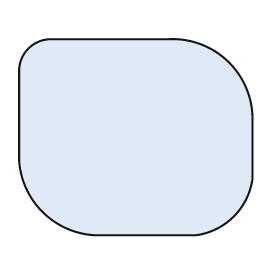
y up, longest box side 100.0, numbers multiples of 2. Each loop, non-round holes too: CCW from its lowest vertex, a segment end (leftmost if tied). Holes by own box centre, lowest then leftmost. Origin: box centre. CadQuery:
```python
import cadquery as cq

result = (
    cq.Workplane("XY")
    .moveTo(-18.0, -42.0)
    .lineTo(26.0, -42.0)
    .threePointArc((42.0, -34.0), (50.0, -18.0))
    .lineTo(50.0, 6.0)
    .threePointArc((40.0, 32.0), (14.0, 42.0))
    .lineTo(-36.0, 42.0)
    .threePointArc((-46.0, 38.0), (-50.0, 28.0))
    .lineTo(-50.0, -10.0)
    .threePointArc((-40.0, -32.0), (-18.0, -42.0))
    .close()
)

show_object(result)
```